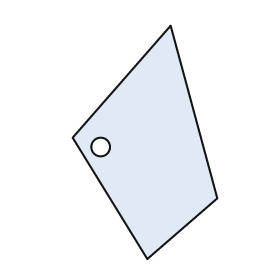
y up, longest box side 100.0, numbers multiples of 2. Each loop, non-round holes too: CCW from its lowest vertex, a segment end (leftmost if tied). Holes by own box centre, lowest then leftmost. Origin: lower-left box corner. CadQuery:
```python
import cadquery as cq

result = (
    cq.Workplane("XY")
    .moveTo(32.0, 0.0)
    .lineTo(62.0, 26.0)
    .lineTo(42.0, 100.0)
    .lineTo(0.0, 52.0)
    .close()
    .moveTo(12.0, 48.0)
    .circle(4.0)
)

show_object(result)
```